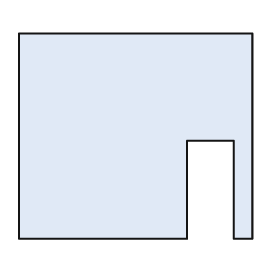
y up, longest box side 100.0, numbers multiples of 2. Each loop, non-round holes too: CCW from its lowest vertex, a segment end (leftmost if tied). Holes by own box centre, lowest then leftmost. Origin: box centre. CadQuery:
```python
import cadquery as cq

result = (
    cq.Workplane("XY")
    .moveTo(-50.0, -44.0)
    .lineTo(22.0, -44.0)
    .lineTo(22.0, -2.0)
    .lineTo(42.0, -2.0)
    .lineTo(42.0, -44.0)
    .lineTo(50.0, -44.0)
    .lineTo(50.0, 44.0)
    .lineTo(-50.0, 44.0)
    .close()
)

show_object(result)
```